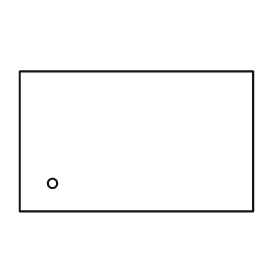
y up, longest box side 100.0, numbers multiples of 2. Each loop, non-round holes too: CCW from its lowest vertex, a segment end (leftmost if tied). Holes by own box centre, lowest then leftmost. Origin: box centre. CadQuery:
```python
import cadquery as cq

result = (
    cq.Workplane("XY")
    .moveTo(-50.0, -30.0)
    .lineTo(50.0, -30.0)
    .lineTo(50.0, 30.0)
    .lineTo(-50.0, 30.0)
    .close()
    .moveTo(-36.0, -18.0)
    .circle(2.0)
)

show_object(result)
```